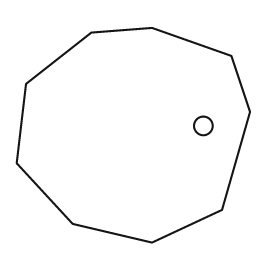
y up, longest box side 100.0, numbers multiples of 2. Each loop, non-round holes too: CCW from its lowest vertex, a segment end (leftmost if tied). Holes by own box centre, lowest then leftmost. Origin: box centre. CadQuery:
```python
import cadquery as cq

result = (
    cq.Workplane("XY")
    .moveTo(8.0, -46.0)
    .lineTo(38.0, -32.0)
    .lineTo(50.0, 10.0)
    .lineTo(42.0, 34.0)
    .lineTo(8.0, 46.0)
    .lineTo(-18.0, 44.0)
    .lineTo(-46.0, 22.0)
    .lineTo(-50.0, -12.0)
    .lineTo(-26.0, -38.0)
    .close()
    .moveTo(30.0, 4.0)
    .circle(4.0)
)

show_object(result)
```